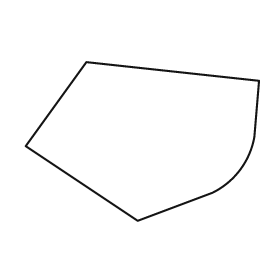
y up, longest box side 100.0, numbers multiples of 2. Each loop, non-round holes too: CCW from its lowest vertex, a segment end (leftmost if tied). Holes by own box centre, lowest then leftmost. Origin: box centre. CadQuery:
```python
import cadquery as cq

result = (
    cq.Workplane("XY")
    .moveTo(-2.0, -34.0)
    .lineTo(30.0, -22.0)
    .threePointArc((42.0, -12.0), (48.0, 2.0))
    .lineTo(50.0, 26.0)
    .lineTo(-24.0, 34.0)
    .lineTo(-50.0, -2.0)
    .close()
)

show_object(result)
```